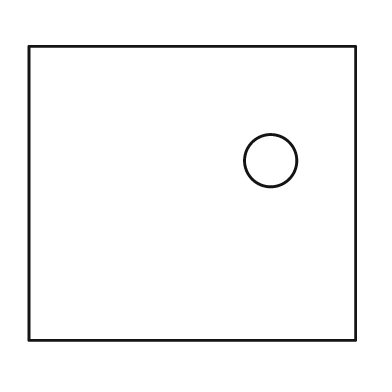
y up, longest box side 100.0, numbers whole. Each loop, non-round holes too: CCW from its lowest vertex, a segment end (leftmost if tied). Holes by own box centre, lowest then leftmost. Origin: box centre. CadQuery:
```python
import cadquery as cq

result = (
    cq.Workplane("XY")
    .moveTo(-50.0, -45.0)
    .lineTo(50.0, -45.0)
    .lineTo(50.0, 45.0)
    .lineTo(-50.0, 45.0)
    .close()
    .moveTo(24.0, 10.0)
    .circle(8.0)
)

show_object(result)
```